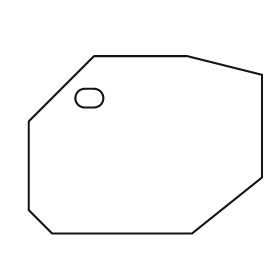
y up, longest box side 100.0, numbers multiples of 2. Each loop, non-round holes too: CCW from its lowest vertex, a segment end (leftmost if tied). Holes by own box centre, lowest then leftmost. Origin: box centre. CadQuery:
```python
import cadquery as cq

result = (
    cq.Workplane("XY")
    .moveTo(-40.0, -38.0)
    .lineTo(20.0, -38.0)
    .lineTo(50.0, -14.0)
    .lineTo(50.0, 30.0)
    .lineTo(18.0, 38.0)
    .lineTo(-22.0, 38.0)
    .lineTo(-50.0, 10.0)
    .lineTo(-50.0, -28.0)
    .close()
    .moveTo(-26.0, 16.0)
    .lineTo(-22.0, 16.0)
    .threePointArc((-18.0, 20.0), (-22.0, 24.0))
    .lineTo(-26.0, 24.0)
    .threePointArc((-30.0, 20.0), (-26.0, 16.0))
    .close()
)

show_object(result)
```